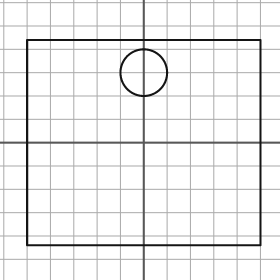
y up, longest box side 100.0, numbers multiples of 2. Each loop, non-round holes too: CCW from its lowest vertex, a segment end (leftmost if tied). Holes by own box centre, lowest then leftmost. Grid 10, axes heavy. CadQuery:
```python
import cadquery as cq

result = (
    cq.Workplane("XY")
    .moveTo(-50.0, -44.0)
    .lineTo(50.0, -44.0)
    .lineTo(50.0, 44.0)
    .lineTo(-50.0, 44.0)
    .close()
    .moveTo(0.0, 30.0)
    .circle(10.0)
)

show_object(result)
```